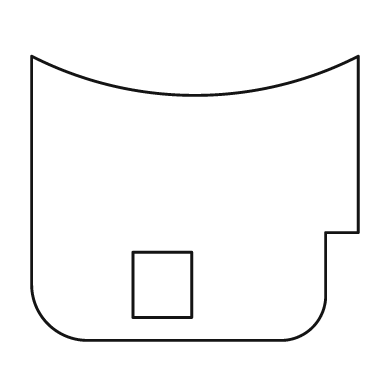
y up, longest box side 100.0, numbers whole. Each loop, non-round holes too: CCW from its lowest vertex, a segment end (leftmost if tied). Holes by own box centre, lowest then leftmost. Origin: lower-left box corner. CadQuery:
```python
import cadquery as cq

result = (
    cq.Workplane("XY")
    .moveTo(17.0, 0.0)
    .lineTo(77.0, 0.0)
    .threePointArc((86.0, 4.0), (90.0, 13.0))
    .lineTo(90.0, 33.0)
    .lineTo(100.0, 33.0)
    .lineTo(100.0, 87.0)
    .threePointArc((50.0, 75.0), (0.0, 87.0))
    .lineTo(0.0, 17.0)
    .threePointArc((5.0, 5.0), (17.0, 0.0))
    .close()
    .moveTo(31.0, 7.0)
    .lineTo(49.0, 7.0)
    .lineTo(49.0, 27.0)
    .lineTo(31.0, 27.0)
    .close()
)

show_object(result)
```